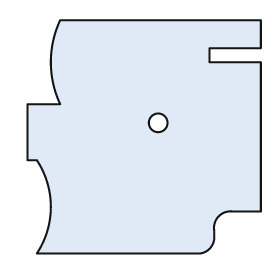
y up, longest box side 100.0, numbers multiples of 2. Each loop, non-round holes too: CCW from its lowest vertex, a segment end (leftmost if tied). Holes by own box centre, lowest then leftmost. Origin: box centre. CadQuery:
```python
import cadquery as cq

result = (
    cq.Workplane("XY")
    .moveTo(-46.0, -50.0)
    .lineTo(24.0, -50.0)
    .threePointArc((28.0, -48.0), (30.0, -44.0))
    .lineTo(30.0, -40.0)
    .threePointArc((32.0, -34.0), (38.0, -32.0))
    .lineTo(50.0, -32.0)
    .lineTo(50.0, 32.0)
    .lineTo(28.0, 32.0)
    .lineTo(28.0, 38.0)
    .lineTo(50.0, 38.0)
    .lineTo(50.0, 50.0)
    .lineTo(-36.0, 50.0)
    .threePointArc((-40.0, 32.0), (-36.0, 14.0))
    .lineTo(-50.0, 14.0)
    .lineTo(-50.0, -10.0)
    .lineTo(-46.0, -10.0)
    .threePointArc((-40.0, -30.0), (-46.0, -50.0))
    .close()
    .moveTo(6.0, 6.0)
    .circle(4.0)
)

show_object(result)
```